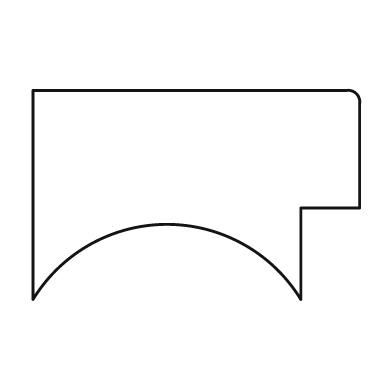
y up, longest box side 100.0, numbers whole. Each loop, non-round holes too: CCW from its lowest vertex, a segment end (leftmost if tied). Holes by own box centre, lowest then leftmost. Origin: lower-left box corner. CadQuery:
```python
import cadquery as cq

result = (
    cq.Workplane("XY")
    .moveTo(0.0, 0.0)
    .threePointArc((41.0, 23.0), (82.0, 0.0))
    .lineTo(82.0, 28.0)
    .lineTo(100.0, 28.0)
    .lineTo(100.0, 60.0)
    .threePointArc((99.0, 63.0), (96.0, 64.0))
    .lineTo(0.0, 64.0)
    .close()
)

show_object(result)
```